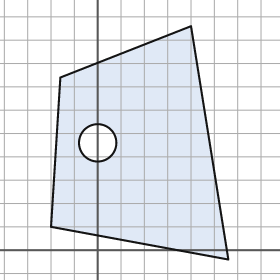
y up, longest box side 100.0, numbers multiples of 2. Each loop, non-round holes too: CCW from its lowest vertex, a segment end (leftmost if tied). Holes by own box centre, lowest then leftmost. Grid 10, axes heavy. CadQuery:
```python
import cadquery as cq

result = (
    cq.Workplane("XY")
    .moveTo(56.0, -4.0)
    .lineTo(40.0, 96.0)
    .lineTo(-16.0, 74.0)
    .lineTo(-20.0, 10.0)
    .close()
    .moveTo(0.0, 46.0)
    .circle(8.0)
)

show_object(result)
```